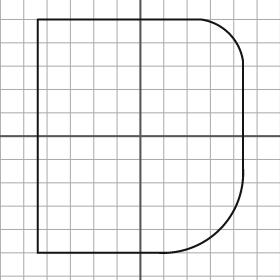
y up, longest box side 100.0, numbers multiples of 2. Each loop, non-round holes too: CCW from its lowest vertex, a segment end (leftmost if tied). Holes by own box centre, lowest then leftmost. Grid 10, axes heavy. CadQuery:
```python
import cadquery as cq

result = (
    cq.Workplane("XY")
    .moveTo(-44.0, -50.0)
    .lineTo(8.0, -50.0)
    .threePointArc((34.0, -40.0), (44.0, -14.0))
    .lineTo(44.0, 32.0)
    .threePointArc((38.0, 44.0), (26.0, 50.0))
    .lineTo(-44.0, 50.0)
    .close()
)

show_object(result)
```